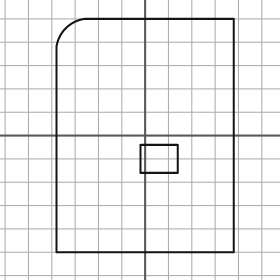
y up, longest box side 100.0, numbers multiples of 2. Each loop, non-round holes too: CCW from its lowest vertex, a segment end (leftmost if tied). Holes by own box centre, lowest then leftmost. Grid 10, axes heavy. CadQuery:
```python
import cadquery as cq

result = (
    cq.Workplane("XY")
    .moveTo(-38.0, -50.0)
    .lineTo(38.0, -50.0)
    .lineTo(38.0, 50.0)
    .lineTo(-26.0, 50.0)
    .threePointArc((-34.0, 46.0), (-38.0, 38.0))
    .close()
    .moveTo(-2.0, -16.0)
    .lineTo(14.0, -16.0)
    .lineTo(14.0, -4.0)
    .lineTo(-2.0, -4.0)
    .close()
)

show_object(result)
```